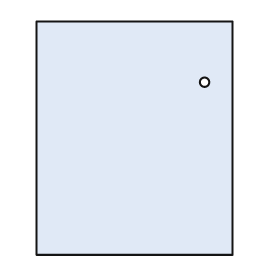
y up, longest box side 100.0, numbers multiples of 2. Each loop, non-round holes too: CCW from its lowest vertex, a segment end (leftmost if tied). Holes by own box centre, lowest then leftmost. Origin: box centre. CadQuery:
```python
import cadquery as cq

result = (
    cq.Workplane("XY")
    .moveTo(-42.0, -50.0)
    .lineTo(42.0, -50.0)
    .lineTo(42.0, 50.0)
    .lineTo(-42.0, 50.0)
    .close()
    .moveTo(30.0, 24.0)
    .circle(2.0)
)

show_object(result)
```